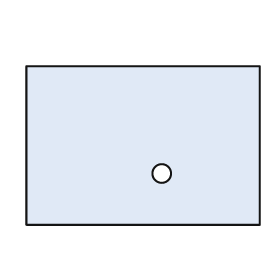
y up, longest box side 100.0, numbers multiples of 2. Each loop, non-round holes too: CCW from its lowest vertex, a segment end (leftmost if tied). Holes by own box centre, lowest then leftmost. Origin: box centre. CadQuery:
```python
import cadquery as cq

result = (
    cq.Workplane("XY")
    .moveTo(-50.0, -34.0)
    .lineTo(50.0, -34.0)
    .lineTo(50.0, 34.0)
    .lineTo(-50.0, 34.0)
    .close()
    .moveTo(8.0, -12.0)
    .circle(4.0)
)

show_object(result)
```